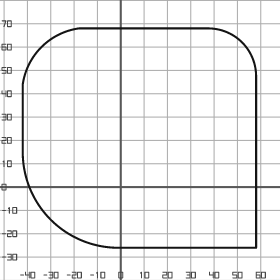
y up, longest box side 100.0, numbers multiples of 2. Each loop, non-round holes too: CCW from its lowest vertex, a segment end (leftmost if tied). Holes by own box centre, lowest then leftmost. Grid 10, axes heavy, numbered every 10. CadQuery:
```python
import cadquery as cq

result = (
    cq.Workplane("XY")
    .moveTo(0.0, -26.0)
    .lineTo(58.0, -26.0)
    .lineTo(58.0, 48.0)
    .threePointArc((52.0, 62.0), (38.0, 68.0))
    .lineTo(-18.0, 68.0)
    .threePointArc((-34.0, 60.0), (-42.0, 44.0))
    .lineTo(-42.0, 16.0)
    .threePointArc((-30.0, -14.0), (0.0, -26.0))
    .close()
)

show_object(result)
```